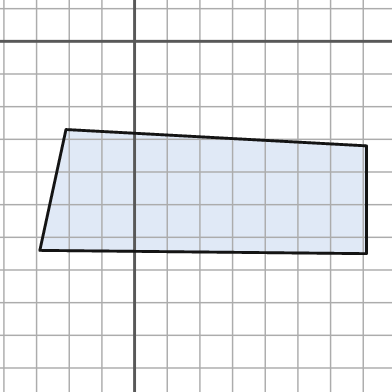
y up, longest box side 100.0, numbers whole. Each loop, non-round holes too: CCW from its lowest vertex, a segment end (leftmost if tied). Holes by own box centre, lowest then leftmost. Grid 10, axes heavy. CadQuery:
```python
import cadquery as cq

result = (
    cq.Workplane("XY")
    .moveTo(71.0, -65.0)
    .lineTo(71.0, -32.0)
    .lineTo(-21.0, -27.0)
    .lineTo(-29.0, -64.0)
    .close()
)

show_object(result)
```